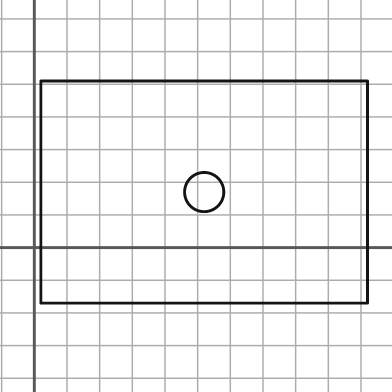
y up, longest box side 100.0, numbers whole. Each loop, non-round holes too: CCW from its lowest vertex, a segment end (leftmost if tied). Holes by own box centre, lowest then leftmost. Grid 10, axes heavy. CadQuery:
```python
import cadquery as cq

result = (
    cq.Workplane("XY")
    .moveTo(2.0, -17.0)
    .lineTo(102.0, -17.0)
    .lineTo(102.0, 51.0)
    .lineTo(2.0, 51.0)
    .close()
    .moveTo(52.0, 17.0)
    .circle(6.0)
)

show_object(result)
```